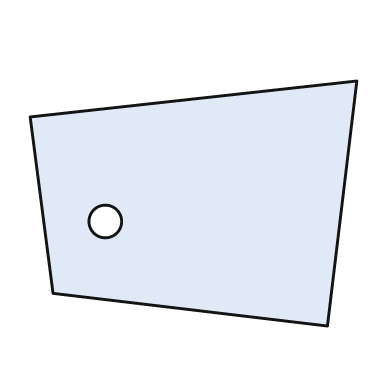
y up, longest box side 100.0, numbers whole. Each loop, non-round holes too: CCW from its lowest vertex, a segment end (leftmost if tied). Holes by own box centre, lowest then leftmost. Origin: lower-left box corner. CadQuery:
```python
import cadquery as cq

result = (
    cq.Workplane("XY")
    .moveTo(91.0, 0.0)
    .lineTo(100.0, 75.0)
    .lineTo(0.0, 64.0)
    .lineTo(7.0, 10.0)
    .close()
    .moveTo(23.0, 32.0)
    .circle(5.0)
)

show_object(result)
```